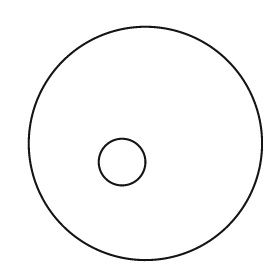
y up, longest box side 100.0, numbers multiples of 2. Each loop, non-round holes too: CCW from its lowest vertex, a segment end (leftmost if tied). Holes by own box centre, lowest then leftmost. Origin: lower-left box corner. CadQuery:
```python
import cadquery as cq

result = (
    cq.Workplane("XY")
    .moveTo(50.0, 50.0)
    .circle(50.0)
    .moveTo(40.0, 42.0)
    .circle(10.0)
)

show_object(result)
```